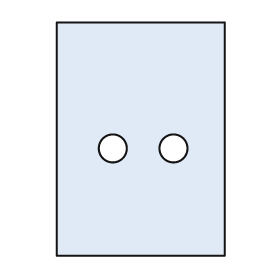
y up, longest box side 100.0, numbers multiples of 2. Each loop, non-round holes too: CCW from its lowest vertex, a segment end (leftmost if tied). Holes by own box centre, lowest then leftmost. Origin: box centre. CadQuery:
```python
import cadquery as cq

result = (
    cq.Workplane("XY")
    .moveTo(-36.0, -50.0)
    .lineTo(36.0, -50.0)
    .lineTo(36.0, 50.0)
    .lineTo(-36.0, 50.0)
    .close()
    .moveTo(-12.0, -4.0)
    .circle(6.0)
    .moveTo(14.0, -4.0)
    .circle(6.0)
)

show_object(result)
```